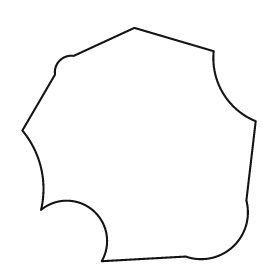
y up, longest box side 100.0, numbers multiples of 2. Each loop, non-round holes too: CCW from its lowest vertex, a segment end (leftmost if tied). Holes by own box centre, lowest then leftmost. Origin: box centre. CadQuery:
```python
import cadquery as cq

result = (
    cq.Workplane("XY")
    .moveTo(-16.0, -50.0)
    .lineTo(20.0, -48.0)
    .threePointArc((40.0, -44.0), (46.0, -24.0))
    .lineTo(50.0, 10.0)
    .threePointArc((36.0, 22.0), (32.0, 40.0))
    .lineTo(-2.0, 50.0)
    .lineTo(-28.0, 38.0)
    .threePointArc((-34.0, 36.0), (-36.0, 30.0))
    .lineTo(-50.0, 6.0)
    .threePointArc((-42.0, -10.0), (-42.0, -28.0))
    .threePointArc((-20.0, -28.0), (-16.0, -50.0))
    .close()
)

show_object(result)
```